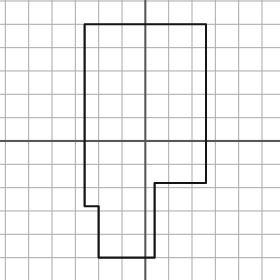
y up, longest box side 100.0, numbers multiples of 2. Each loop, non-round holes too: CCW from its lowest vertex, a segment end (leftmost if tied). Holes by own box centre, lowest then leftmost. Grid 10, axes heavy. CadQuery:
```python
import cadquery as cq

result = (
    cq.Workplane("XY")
    .moveTo(-20.0, -50.0)
    .lineTo(4.0, -50.0)
    .lineTo(4.0, -18.0)
    .lineTo(26.0, -18.0)
    .lineTo(26.0, 50.0)
    .lineTo(-26.0, 50.0)
    .lineTo(-26.0, -28.0)
    .lineTo(-20.0, -28.0)
    .close()
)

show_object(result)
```